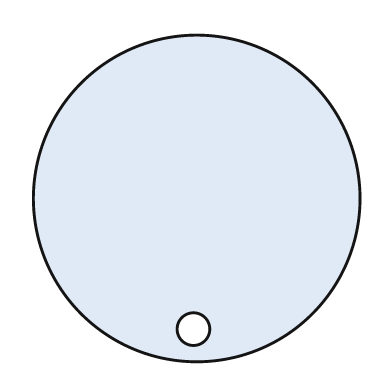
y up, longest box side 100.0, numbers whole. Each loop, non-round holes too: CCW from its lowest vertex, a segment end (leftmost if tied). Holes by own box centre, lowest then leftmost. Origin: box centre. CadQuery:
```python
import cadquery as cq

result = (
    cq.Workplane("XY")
    .moveTo(0.0, 0.0)
    .circle(50.0)
    .moveTo(-1.0, -40.0)
    .circle(5.0)
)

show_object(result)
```